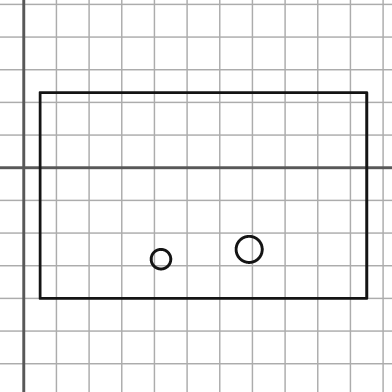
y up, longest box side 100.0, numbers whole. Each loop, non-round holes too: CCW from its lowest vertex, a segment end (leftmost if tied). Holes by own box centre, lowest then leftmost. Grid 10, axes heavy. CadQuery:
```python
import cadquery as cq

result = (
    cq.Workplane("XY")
    .moveTo(5.0, -40.0)
    .lineTo(105.0, -40.0)
    .lineTo(105.0, 23.0)
    .lineTo(5.0, 23.0)
    .close()
    .moveTo(42.0, -28.0)
    .circle(3.0)
    .moveTo(69.0, -25.0)
    .circle(4.0)
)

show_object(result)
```